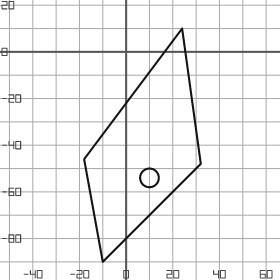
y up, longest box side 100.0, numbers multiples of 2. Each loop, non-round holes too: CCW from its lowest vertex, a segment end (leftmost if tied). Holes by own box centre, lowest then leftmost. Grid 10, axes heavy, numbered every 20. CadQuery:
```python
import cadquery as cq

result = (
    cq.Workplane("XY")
    .moveTo(-10.0, -90.0)
    .lineTo(32.0, -48.0)
    .lineTo(24.0, 10.0)
    .lineTo(-18.0, -46.0)
    .close()
    .moveTo(10.0, -54.0)
    .circle(4.0)
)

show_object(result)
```